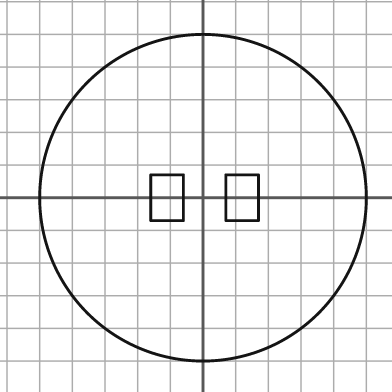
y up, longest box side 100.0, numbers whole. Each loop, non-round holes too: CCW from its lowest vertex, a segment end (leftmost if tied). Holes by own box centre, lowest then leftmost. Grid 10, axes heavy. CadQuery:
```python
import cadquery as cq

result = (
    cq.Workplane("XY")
    .moveTo(0.0, 0.0)
    .circle(50.0)
    .moveTo(-16.0, -7.0)
    .lineTo(-6.0, -7.0)
    .lineTo(-6.0, 7.0)
    .lineTo(-16.0, 7.0)
    .close()
    .moveTo(7.0, -7.0)
    .lineTo(17.0, -7.0)
    .lineTo(17.0, 7.0)
    .lineTo(7.0, 7.0)
    .close()
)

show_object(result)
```